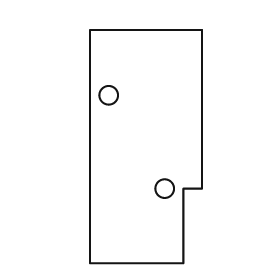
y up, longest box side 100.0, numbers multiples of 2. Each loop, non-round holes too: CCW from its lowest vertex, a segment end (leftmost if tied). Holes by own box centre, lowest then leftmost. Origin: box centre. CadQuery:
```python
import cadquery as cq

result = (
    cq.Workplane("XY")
    .moveTo(-24.0, -50.0)
    .lineTo(16.0, -50.0)
    .lineTo(16.0, -18.0)
    .lineTo(24.0, -18.0)
    .lineTo(24.0, 50.0)
    .lineTo(-24.0, 50.0)
    .close()
    .moveTo(8.0, -18.0)
    .circle(4.0)
    .moveTo(-16.0, 22.0)
    .circle(4.0)
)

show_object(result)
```